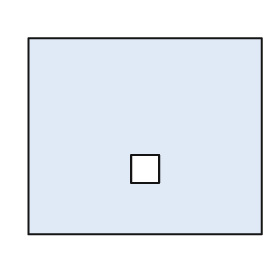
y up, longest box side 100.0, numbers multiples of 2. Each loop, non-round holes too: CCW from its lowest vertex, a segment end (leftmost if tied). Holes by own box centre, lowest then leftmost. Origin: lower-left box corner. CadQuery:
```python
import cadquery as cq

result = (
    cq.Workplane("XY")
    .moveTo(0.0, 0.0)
    .lineTo(100.0, 0.0)
    .lineTo(100.0, 84.0)
    .lineTo(0.0, 84.0)
    .close()
    .moveTo(44.0, 22.0)
    .lineTo(56.0, 22.0)
    .lineTo(56.0, 34.0)
    .lineTo(44.0, 34.0)
    .close()
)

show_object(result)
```